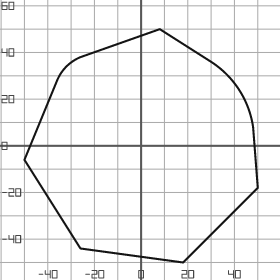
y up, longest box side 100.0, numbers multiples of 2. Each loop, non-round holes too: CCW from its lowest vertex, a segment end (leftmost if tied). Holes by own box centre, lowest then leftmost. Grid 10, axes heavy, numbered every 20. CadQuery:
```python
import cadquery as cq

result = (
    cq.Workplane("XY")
    .moveTo(18.0, -50.0)
    .lineTo(50.0, -18.0)
    .lineTo(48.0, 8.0)
    .threePointArc((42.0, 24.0), (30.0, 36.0))
    .lineTo(8.0, 50.0)
    .lineTo(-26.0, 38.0)
    .threePointArc((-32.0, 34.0), (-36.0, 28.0))
    .lineTo(-50.0, -6.0)
    .lineTo(-26.0, -44.0)
    .close()
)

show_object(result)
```